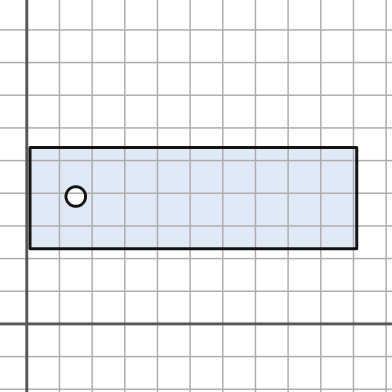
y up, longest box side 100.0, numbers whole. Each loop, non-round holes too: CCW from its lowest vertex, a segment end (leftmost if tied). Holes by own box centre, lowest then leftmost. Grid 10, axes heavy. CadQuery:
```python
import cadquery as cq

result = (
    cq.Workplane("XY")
    .moveTo(1.0, 23.0)
    .lineTo(101.0, 23.0)
    .lineTo(101.0, 54.0)
    .lineTo(1.0, 54.0)
    .close()
    .moveTo(15.0, 39.0)
    .circle(3.0)
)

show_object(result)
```